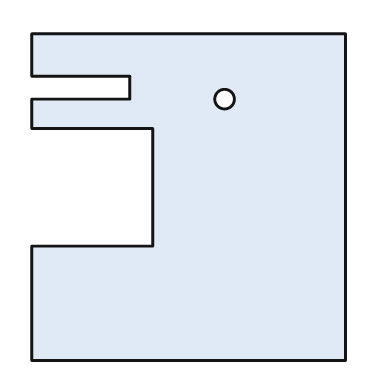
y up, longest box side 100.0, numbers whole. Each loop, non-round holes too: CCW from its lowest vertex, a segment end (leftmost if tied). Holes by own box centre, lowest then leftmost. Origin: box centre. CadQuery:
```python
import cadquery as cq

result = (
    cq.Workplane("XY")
    .moveTo(-48.0, -50.0)
    .lineTo(48.0, -50.0)
    .lineTo(48.0, 50.0)
    .lineTo(-48.0, 50.0)
    .lineTo(-48.0, 37.0)
    .lineTo(-18.0, 37.0)
    .lineTo(-18.0, 30.0)
    .lineTo(-48.0, 30.0)
    .lineTo(-48.0, 21.0)
    .lineTo(-11.0, 21.0)
    .lineTo(-11.0, -15.0)
    .lineTo(-48.0, -15.0)
    .close()
    .moveTo(11.0, 30.0)
    .circle(3.0)
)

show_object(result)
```